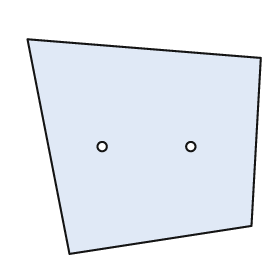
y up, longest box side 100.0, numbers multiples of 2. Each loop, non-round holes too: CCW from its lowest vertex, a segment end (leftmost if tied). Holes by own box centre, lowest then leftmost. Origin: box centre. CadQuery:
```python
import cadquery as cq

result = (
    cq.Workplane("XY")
    .moveTo(-32.0, -46.0)
    .lineTo(46.0, -34.0)
    .lineTo(50.0, 38.0)
    .lineTo(-50.0, 46.0)
    .close()
    .moveTo(-18.0, 0.0)
    .circle(2.0)
    .moveTo(20.0, 0.0)
    .circle(2.0)
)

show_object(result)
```